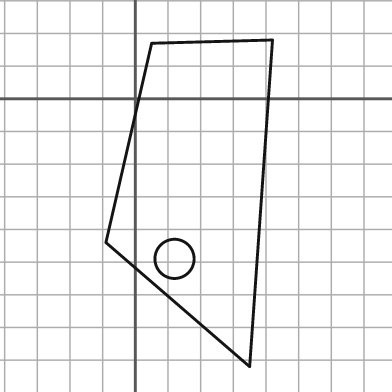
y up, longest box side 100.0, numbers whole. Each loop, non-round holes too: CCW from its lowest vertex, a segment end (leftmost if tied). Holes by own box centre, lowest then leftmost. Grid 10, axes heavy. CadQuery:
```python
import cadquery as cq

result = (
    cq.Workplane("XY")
    .moveTo(35.0, -82.0)
    .lineTo(42.0, 18.0)
    .lineTo(5.0, 17.0)
    .lineTo(-9.0, -44.0)
    .close()
    .moveTo(12.0, -49.0)
    .circle(6.0)
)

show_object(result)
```